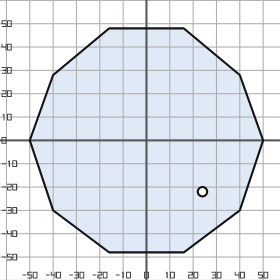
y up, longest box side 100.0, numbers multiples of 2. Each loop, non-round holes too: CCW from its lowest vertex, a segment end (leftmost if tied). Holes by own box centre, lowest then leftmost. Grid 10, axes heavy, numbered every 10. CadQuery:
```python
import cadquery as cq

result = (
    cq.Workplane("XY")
    .moveTo(-16.0, -48.0)
    .lineTo(16.0, -48.0)
    .lineTo(40.0, -30.0)
    .lineTo(50.0, 0.0)
    .lineTo(40.0, 28.0)
    .lineTo(16.0, 48.0)
    .lineTo(-16.0, 48.0)
    .lineTo(-40.0, 28.0)
    .lineTo(-50.0, 0.0)
    .lineTo(-40.0, -30.0)
    .close()
    .moveTo(24.0, -22.0)
    .circle(2.0)
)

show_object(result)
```